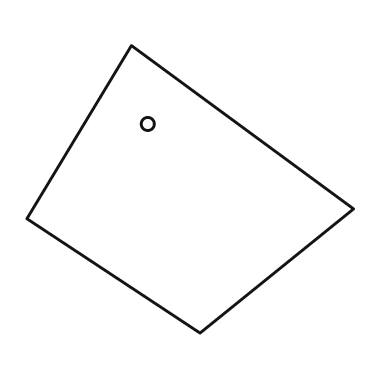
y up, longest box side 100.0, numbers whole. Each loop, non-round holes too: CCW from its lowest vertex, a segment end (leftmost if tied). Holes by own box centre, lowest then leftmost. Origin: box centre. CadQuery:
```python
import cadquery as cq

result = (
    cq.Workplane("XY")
    .moveTo(3.0, -44.0)
    .lineTo(50.0, -6.0)
    .lineTo(-18.0, 44.0)
    .lineTo(-50.0, -9.0)
    .close()
    .moveTo(-13.0, 20.0)
    .circle(2.0)
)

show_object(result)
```